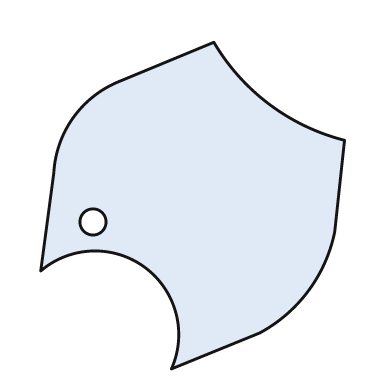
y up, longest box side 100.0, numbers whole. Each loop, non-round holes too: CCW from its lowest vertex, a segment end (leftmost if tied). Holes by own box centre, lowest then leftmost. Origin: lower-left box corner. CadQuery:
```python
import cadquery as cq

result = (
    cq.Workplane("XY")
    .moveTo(40.0, 0.0)
    .lineTo(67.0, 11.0)
    .threePointArc((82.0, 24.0), (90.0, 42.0))
    .lineTo(93.0, 70.0)
    .threePointArc((70.0, 81.0), (53.0, 100.0))
    .lineTo(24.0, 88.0)
    .threePointArc((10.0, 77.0), (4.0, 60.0))
    .lineTo(0.0, 30.0)
    .threePointArc((32.0, 31.0), (40.0, 0.0))
    .close()
    .moveTo(16.0, 45.0)
    .circle(4.0)
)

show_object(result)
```